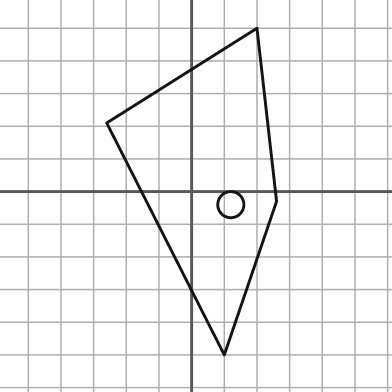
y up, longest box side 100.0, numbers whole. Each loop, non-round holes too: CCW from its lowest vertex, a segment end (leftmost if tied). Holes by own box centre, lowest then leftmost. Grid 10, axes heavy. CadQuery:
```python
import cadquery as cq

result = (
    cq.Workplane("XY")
    .moveTo(10.0, -50.0)
    .lineTo(26.0, -3.0)
    .lineTo(20.0, 50.0)
    .lineTo(-26.0, 21.0)
    .close()
    .moveTo(12.0, -4.0)
    .circle(4.0)
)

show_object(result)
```